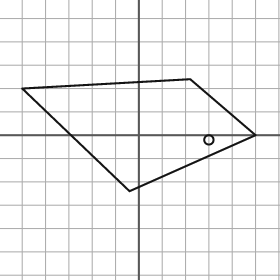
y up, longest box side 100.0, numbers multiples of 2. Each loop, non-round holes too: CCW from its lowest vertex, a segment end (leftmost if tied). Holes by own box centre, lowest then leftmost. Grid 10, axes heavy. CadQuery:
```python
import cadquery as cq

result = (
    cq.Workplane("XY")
    .moveTo(-4.0, -24.0)
    .lineTo(50.0, 0.0)
    .lineTo(22.0, 24.0)
    .lineTo(-50.0, 20.0)
    .close()
    .moveTo(30.0, -2.0)
    .circle(2.0)
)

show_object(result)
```